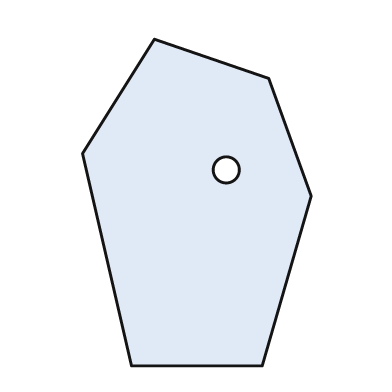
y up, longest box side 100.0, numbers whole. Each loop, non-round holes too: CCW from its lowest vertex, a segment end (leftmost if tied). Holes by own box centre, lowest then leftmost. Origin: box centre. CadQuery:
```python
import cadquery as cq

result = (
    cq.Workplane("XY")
    .moveTo(-20.0, -50.0)
    .lineTo(20.0, -50.0)
    .lineTo(35.0, 2.0)
    .lineTo(22.0, 38.0)
    .lineTo(-13.0, 50.0)
    .lineTo(-35.0, 15.0)
    .close()
    .moveTo(9.0, 10.0)
    .circle(4.0)
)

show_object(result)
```